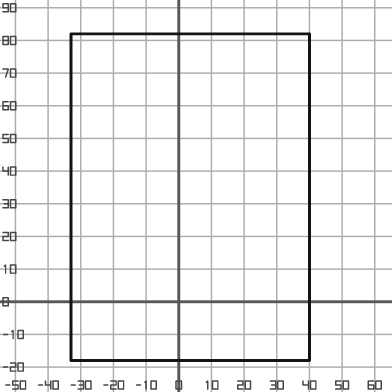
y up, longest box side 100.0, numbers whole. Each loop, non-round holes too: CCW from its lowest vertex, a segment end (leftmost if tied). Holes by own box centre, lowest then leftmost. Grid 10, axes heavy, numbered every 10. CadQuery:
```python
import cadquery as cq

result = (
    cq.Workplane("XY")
    .moveTo(-33.0, -18.0)
    .lineTo(40.0, -18.0)
    .lineTo(40.0, 82.0)
    .lineTo(-33.0, 82.0)
    .close()
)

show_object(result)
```